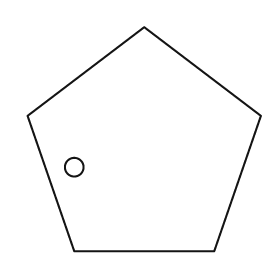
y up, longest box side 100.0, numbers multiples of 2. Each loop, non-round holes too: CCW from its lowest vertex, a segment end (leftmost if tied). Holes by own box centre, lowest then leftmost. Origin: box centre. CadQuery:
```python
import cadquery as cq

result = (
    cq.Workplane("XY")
    .moveTo(-30.0, -48.0)
    .lineTo(30.0, -48.0)
    .lineTo(50.0, 10.0)
    .lineTo(0.0, 48.0)
    .lineTo(-50.0, 10.0)
    .close()
    .moveTo(-30.0, -12.0)
    .circle(4.0)
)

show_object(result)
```